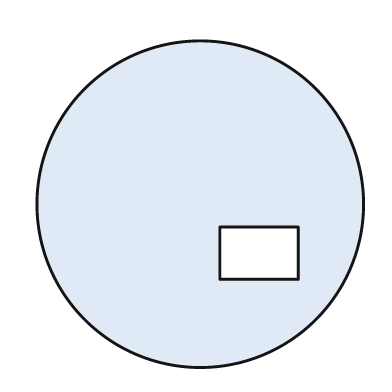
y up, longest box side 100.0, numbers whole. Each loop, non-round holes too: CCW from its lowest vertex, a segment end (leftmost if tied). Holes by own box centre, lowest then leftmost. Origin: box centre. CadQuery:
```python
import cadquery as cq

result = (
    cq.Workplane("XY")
    .moveTo(0.0, 0.0)
    .circle(50.0)
    .moveTo(6.0, -23.0)
    .lineTo(30.0, -23.0)
    .lineTo(30.0, -7.0)
    .lineTo(6.0, -7.0)
    .close()
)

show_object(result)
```